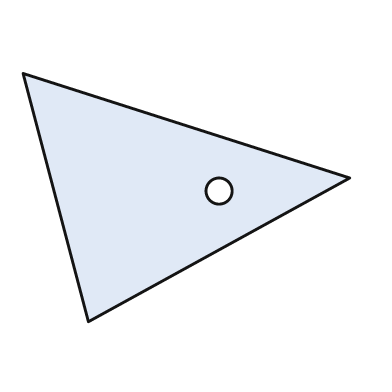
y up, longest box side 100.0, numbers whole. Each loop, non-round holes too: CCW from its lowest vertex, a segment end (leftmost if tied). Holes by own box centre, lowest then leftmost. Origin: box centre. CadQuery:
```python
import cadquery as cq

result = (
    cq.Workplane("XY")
    .moveTo(-30.0, -38.0)
    .lineTo(50.0, 6.0)
    .lineTo(-50.0, 38.0)
    .close()
    .moveTo(10.0, 2.0)
    .circle(4.0)
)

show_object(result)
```